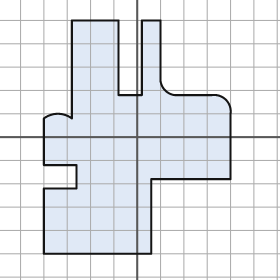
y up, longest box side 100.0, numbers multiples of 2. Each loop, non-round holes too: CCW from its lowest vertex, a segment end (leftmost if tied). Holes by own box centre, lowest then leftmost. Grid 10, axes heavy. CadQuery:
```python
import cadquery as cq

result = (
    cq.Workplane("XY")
    .moveTo(-40.0, -50.0)
    .lineTo(6.0, -50.0)
    .lineTo(6.0, -18.0)
    .lineTo(40.0, -18.0)
    .lineTo(40.0, 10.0)
    .threePointArc((38.0, 16.0), (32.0, 18.0))
    .lineTo(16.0, 18.0)
    .threePointArc((12.0, 20.0), (10.0, 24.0))
    .lineTo(10.0, 50.0)
    .lineTo(2.0, 50.0)
    .lineTo(2.0, 18.0)
    .lineTo(-8.0, 18.0)
    .lineTo(-8.0, 50.0)
    .lineTo(-28.0, 50.0)
    .lineTo(-28.0, 8.0)
    .threePointArc((-34.0, 10.0), (-40.0, 8.0))
    .lineTo(-40.0, -12.0)
    .lineTo(-26.0, -12.0)
    .lineTo(-26.0, -22.0)
    .lineTo(-40.0, -22.0)
    .close()
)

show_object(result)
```